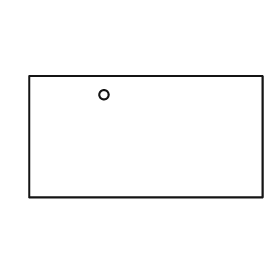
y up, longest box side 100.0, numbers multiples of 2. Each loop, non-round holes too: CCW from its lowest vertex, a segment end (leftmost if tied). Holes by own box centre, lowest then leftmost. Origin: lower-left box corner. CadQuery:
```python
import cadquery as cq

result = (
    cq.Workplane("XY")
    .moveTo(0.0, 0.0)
    .lineTo(100.0, 0.0)
    .lineTo(100.0, 52.0)
    .lineTo(0.0, 52.0)
    .close()
    .moveTo(32.0, 44.0)
    .circle(2.0)
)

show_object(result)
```